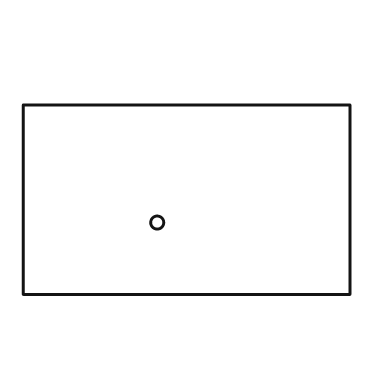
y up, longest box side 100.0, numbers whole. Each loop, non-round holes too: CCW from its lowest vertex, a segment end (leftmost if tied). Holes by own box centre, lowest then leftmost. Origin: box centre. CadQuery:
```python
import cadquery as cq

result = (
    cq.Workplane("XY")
    .moveTo(-50.0, -29.0)
    .lineTo(50.0, -29.0)
    .lineTo(50.0, 29.0)
    .lineTo(-50.0, 29.0)
    .close()
    .moveTo(-9.0, -7.0)
    .circle(2.0)
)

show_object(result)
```